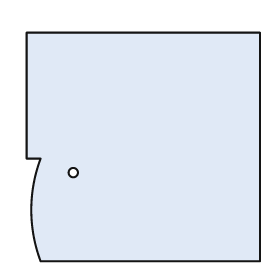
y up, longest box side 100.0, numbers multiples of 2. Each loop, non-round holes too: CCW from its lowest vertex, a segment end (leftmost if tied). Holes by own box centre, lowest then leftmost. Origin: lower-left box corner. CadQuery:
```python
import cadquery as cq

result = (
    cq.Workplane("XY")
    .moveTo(6.0, 0.0)
    .lineTo(100.0, 0.0)
    .lineTo(100.0, 98.0)
    .lineTo(0.0, 98.0)
    .lineTo(0.0, 44.0)
    .lineTo(6.0, 44.0)
    .threePointArc((2.0, 22.0), (6.0, 0.0))
    .close()
    .moveTo(20.0, 38.0)
    .circle(2.0)
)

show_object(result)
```